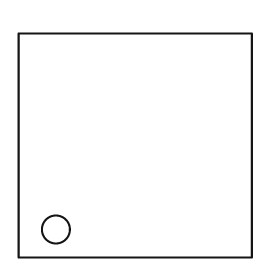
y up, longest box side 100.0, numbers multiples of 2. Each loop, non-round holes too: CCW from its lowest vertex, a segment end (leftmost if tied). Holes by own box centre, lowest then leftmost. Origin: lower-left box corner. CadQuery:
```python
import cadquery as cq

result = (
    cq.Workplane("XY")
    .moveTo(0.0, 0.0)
    .lineTo(100.0, 0.0)
    .lineTo(100.0, 96.0)
    .lineTo(0.0, 96.0)
    .close()
    .moveTo(16.0, 12.0)
    .circle(6.0)
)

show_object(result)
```